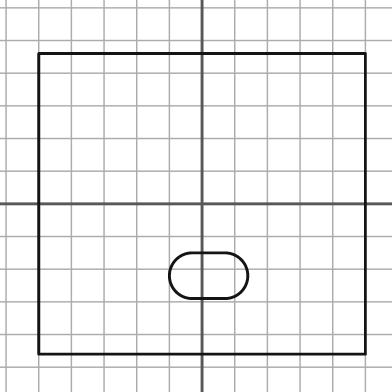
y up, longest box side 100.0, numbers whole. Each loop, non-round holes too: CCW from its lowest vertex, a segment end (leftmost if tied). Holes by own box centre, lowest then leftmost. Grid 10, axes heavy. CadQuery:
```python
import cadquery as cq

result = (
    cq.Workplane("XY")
    .moveTo(-50.0, -46.0)
    .lineTo(50.0, -46.0)
    .lineTo(50.0, 46.0)
    .lineTo(-50.0, 46.0)
    .close()
    .moveTo(-3.0, -29.0)
    .lineTo(7.0, -29.0)
    .threePointArc((14.0, -22.0), (7.0, -15.0))
    .lineTo(-3.0, -15.0)
    .threePointArc((-10.0, -22.0), (-3.0, -29.0))
    .close()
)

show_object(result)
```